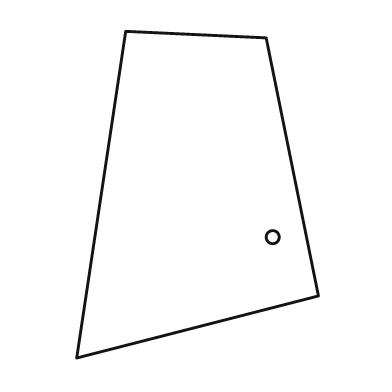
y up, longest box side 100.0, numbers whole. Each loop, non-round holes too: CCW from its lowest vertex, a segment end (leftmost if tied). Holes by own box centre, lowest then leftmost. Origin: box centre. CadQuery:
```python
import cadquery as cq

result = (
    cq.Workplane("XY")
    .moveTo(-37.0, -50.0)
    .lineTo(37.0, -31.0)
    .lineTo(21.0, 48.0)
    .lineTo(-22.0, 50.0)
    .close()
    .moveTo(23.0, -13.0)
    .circle(2.0)
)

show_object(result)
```